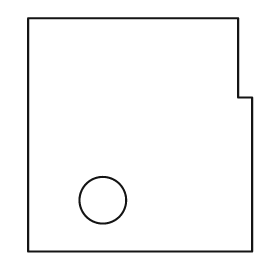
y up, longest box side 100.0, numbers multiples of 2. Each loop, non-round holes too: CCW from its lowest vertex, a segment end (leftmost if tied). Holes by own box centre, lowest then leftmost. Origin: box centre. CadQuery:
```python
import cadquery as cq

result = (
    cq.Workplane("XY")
    .moveTo(-48.0, -50.0)
    .lineTo(48.0, -50.0)
    .lineTo(48.0, 16.0)
    .lineTo(42.0, 16.0)
    .lineTo(42.0, 50.0)
    .lineTo(-48.0, 50.0)
    .close()
    .moveTo(-16.0, -28.0)
    .circle(10.0)
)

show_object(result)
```